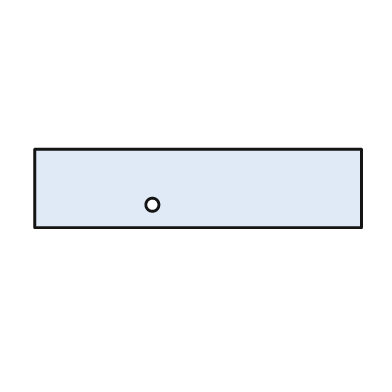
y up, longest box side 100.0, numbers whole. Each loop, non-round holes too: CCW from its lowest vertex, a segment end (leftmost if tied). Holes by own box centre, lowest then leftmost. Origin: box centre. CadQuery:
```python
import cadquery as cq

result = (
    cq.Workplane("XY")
    .moveTo(-50.0, -12.0)
    .lineTo(50.0, -12.0)
    .lineTo(50.0, 12.0)
    .lineTo(-50.0, 12.0)
    .close()
    .moveTo(-14.0, -5.0)
    .circle(2.0)
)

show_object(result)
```